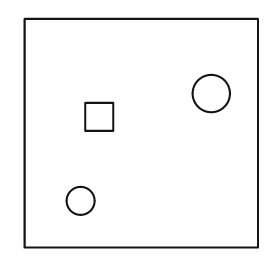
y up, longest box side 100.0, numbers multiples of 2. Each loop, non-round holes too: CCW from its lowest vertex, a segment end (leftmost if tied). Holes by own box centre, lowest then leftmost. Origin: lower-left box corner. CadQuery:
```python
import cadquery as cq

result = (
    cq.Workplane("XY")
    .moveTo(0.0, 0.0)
    .lineTo(100.0, 0.0)
    .lineTo(100.0, 98.0)
    .lineTo(0.0, 98.0)
    .close()
    .moveTo(24.0, 20.0)
    .circle(6.0)
    .moveTo(26.0, 50.0)
    .lineTo(38.0, 50.0)
    .lineTo(38.0, 62.0)
    .lineTo(26.0, 62.0)
    .close()
    .moveTo(80.0, 66.0)
    .circle(8.0)
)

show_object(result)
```